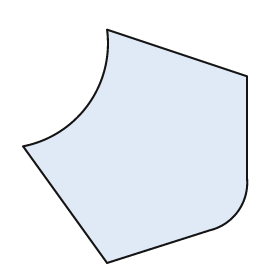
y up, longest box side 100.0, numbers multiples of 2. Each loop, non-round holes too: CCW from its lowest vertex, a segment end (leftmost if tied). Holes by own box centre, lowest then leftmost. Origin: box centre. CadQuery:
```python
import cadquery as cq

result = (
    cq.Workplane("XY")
    .moveTo(-12.0, -50.0)
    .lineTo(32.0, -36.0)
    .threePointArc((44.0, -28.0), (48.0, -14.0))
    .lineTo(48.0, 30.0)
    .lineTo(-12.0, 50.0)
    .threePointArc((-20.0, 18.0), (-48.0, 0.0))
    .close()
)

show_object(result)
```